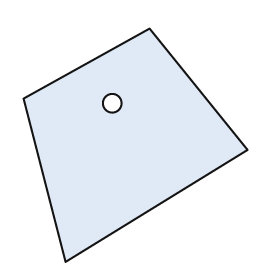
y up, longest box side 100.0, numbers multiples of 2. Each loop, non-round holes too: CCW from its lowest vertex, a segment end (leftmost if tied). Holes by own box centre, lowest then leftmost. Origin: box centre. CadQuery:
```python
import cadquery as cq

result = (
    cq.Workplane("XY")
    .moveTo(-30.0, -50.0)
    .lineTo(48.0, -2.0)
    .lineTo(6.0, 50.0)
    .lineTo(-48.0, 20.0)
    .close()
    .moveTo(-10.0, 18.0)
    .circle(4.0)
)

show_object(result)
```